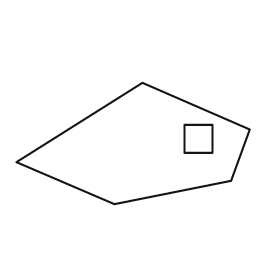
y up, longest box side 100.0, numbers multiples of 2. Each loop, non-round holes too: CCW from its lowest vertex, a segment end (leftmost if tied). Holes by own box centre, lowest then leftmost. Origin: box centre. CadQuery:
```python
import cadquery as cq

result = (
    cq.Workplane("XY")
    .moveTo(-8.0, -26.0)
    .lineTo(42.0, -16.0)
    .lineTo(50.0, 6.0)
    .lineTo(4.0, 26.0)
    .lineTo(-50.0, -8.0)
    .close()
    .moveTo(22.0, -4.0)
    .lineTo(34.0, -4.0)
    .lineTo(34.0, 8.0)
    .lineTo(22.0, 8.0)
    .close()
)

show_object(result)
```